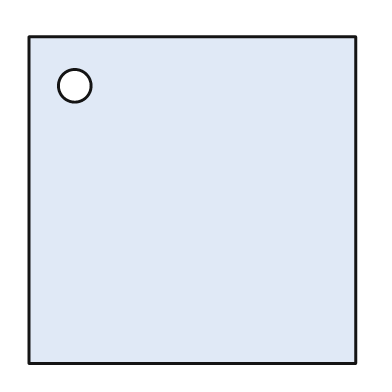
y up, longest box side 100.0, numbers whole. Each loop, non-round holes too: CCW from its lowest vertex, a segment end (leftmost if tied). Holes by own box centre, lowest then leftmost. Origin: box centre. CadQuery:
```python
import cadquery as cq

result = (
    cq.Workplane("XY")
    .moveTo(-50.0, -50.0)
    .lineTo(50.0, -50.0)
    .lineTo(50.0, 50.0)
    .lineTo(-50.0, 50.0)
    .close()
    .moveTo(-36.0, 35.0)
    .circle(5.0)
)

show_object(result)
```